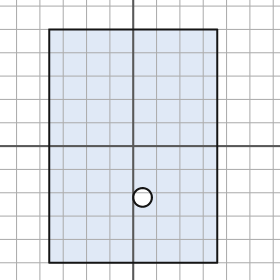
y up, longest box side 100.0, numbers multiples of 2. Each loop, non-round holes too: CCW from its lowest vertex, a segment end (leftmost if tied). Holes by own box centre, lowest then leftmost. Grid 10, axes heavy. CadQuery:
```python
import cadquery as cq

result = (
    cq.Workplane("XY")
    .moveTo(-36.0, -50.0)
    .lineTo(36.0, -50.0)
    .lineTo(36.0, 50.0)
    .lineTo(-36.0, 50.0)
    .close()
    .moveTo(4.0, -22.0)
    .circle(4.0)
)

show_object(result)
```